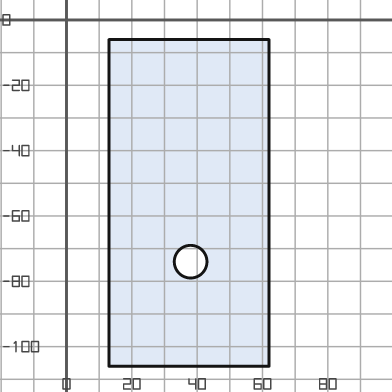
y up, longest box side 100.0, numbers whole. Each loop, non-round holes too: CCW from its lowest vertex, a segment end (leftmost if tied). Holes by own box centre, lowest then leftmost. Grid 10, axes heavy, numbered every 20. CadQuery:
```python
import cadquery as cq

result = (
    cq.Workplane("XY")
    .moveTo(13.0, -106.0)
    .lineTo(62.0, -106.0)
    .lineTo(62.0, -6.0)
    .lineTo(13.0, -6.0)
    .close()
    .moveTo(38.0, -74.0)
    .circle(5.0)
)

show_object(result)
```